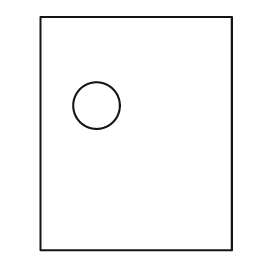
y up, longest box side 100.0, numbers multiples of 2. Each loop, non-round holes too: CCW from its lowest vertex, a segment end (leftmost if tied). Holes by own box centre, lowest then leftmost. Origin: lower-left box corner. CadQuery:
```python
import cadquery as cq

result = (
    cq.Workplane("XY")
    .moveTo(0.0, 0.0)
    .lineTo(82.0, 0.0)
    .lineTo(82.0, 100.0)
    .lineTo(0.0, 100.0)
    .close()
    .moveTo(24.0, 62.0)
    .circle(10.0)
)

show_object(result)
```